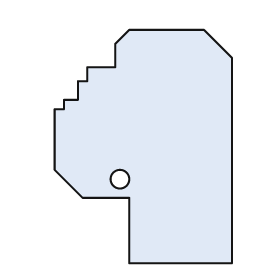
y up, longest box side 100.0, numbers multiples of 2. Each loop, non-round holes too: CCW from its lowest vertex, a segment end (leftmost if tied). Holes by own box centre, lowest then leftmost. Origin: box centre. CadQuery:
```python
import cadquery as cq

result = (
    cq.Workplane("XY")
    .moveTo(-6.0, -50.0)
    .lineTo(38.0, -50.0)
    .lineTo(38.0, 38.0)
    .lineTo(26.0, 50.0)
    .lineTo(-6.0, 50.0)
    .lineTo(-12.0, 44.0)
    .lineTo(-12.0, 34.0)
    .lineTo(-24.0, 34.0)
    .lineTo(-24.0, 28.0)
    .lineTo(-28.0, 28.0)
    .lineTo(-28.0, 20.0)
    .lineTo(-34.0, 20.0)
    .lineTo(-34.0, 16.0)
    .lineTo(-38.0, 16.0)
    .lineTo(-38.0, -10.0)
    .lineTo(-26.0, -22.0)
    .lineTo(-6.0, -22.0)
    .close()
    .moveTo(-10.0, -14.0)
    .circle(4.0)
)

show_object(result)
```